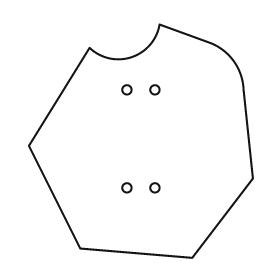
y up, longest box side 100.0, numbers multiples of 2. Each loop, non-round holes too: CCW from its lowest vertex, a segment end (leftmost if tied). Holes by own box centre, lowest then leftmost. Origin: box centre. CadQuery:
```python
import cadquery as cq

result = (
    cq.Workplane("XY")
    .moveTo(22.0, -50.0)
    .lineTo(48.0, -16.0)
    .lineTo(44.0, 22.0)
    .threePointArc((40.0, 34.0), (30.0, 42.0))
    .lineTo(8.0, 50.0)
    .threePointArc((-4.0, 36.0), (-22.0, 40.0))
    .lineTo(-48.0, -2.0)
    .lineTo(-26.0, -46.0)
    .close()
    .moveTo(-6.0, -20.0)
    .circle(2.0)
    .moveTo(6.0, -20.0)
    .circle(2.0)
    .moveTo(-6.0, 22.0)
    .circle(2.0)
    .moveTo(6.0, 22.0)
    .circle(2.0)
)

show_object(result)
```